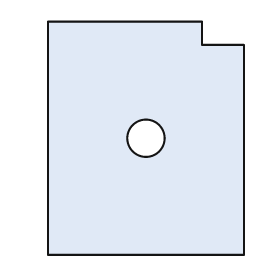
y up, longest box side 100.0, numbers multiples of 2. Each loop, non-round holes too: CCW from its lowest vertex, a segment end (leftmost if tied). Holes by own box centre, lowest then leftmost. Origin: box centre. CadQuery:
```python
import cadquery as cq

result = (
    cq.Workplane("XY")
    .moveTo(-42.0, -50.0)
    .lineTo(42.0, -50.0)
    .lineTo(42.0, 40.0)
    .lineTo(24.0, 40.0)
    .lineTo(24.0, 50.0)
    .lineTo(-42.0, 50.0)
    .close()
    .moveTo(0.0, 0.0)
    .circle(8.0)
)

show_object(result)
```